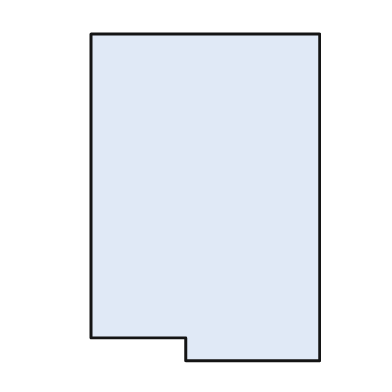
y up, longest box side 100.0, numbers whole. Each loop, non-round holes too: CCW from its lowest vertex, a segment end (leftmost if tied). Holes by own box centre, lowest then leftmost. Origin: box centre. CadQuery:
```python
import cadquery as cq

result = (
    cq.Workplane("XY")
    .moveTo(-6.0, -50.0)
    .lineTo(35.0, -50.0)
    .lineTo(35.0, 50.0)
    .lineTo(-35.0, 50.0)
    .lineTo(-35.0, -43.0)
    .lineTo(-6.0, -43.0)
    .close()
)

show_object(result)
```